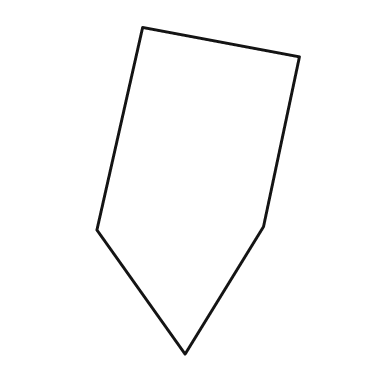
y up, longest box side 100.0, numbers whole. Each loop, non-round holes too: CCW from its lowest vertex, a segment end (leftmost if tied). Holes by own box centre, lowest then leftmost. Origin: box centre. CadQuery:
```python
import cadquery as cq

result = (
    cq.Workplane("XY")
    .moveTo(-4.0, -50.0)
    .lineTo(20.0, -11.0)
    .lineTo(31.0, 41.0)
    .lineTo(-17.0, 50.0)
    .lineTo(-31.0, -12.0)
    .close()
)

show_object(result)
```